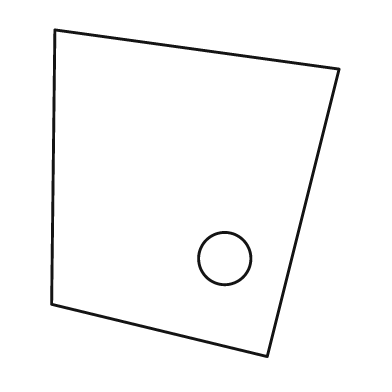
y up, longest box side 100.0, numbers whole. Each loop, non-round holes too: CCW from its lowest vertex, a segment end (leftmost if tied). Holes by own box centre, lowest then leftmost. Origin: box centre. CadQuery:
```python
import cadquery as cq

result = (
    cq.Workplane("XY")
    .moveTo(22.0, -50.0)
    .lineTo(44.0, 38.0)
    .lineTo(-43.0, 50.0)
    .lineTo(-44.0, -34.0)
    .close()
    .moveTo(9.0, -20.0)
    .circle(8.0)
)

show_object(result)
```